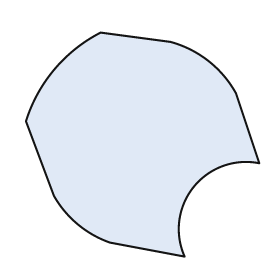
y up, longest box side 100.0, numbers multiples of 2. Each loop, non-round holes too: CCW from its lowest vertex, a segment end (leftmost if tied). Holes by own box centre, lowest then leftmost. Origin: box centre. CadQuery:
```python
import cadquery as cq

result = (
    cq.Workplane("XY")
    .moveTo(18.0, -48.0)
    .threePointArc((22.0, -18.0), (50.0, -8.0))
    .lineTo(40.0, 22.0)
    .threePointArc((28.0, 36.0), (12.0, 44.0))
    .lineTo(-18.0, 48.0)
    .threePointArc((-38.0, 32.0), (-50.0, 10.0))
    .lineTo(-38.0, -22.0)
    .threePointArc((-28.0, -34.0), (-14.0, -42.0))
    .close()
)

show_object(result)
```